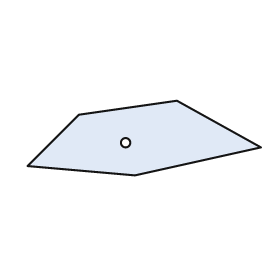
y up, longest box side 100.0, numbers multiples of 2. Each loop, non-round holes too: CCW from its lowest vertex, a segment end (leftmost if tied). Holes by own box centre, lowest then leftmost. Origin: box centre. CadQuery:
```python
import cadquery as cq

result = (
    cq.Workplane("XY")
    .moveTo(-4.0, -16.0)
    .lineTo(50.0, -4.0)
    .lineTo(14.0, 16.0)
    .lineTo(-28.0, 10.0)
    .lineTo(-50.0, -12.0)
    .close()
    .moveTo(-8.0, -2.0)
    .circle(2.0)
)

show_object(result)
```